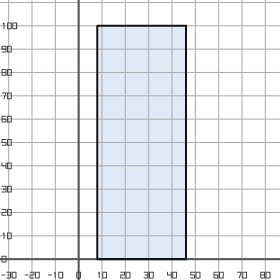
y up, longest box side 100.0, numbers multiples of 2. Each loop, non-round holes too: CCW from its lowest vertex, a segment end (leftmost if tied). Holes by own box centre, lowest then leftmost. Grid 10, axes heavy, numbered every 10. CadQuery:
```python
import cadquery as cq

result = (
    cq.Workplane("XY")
    .moveTo(8.0, 0.0)
    .lineTo(46.0, 0.0)
    .lineTo(46.0, 100.0)
    .lineTo(8.0, 100.0)
    .close()
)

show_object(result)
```